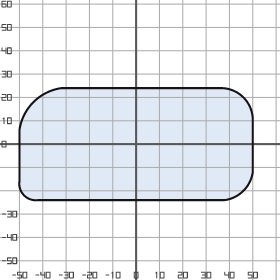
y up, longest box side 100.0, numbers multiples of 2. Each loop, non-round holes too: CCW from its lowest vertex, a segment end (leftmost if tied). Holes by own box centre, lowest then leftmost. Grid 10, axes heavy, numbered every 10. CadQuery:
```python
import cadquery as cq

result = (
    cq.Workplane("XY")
    .moveTo(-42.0, -24.0)
    .lineTo(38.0, -24.0)
    .threePointArc((46.0, -20.0), (50.0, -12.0))
    .lineTo(50.0, 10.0)
    .threePointArc((46.0, 20.0), (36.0, 24.0))
    .lineTo(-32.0, 24.0)
    .threePointArc((-44.0, 18.0), (-50.0, 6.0))
    .lineTo(-50.0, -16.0)
    .threePointArc((-48.0, -22.0), (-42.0, -24.0))
    .close()
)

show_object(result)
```